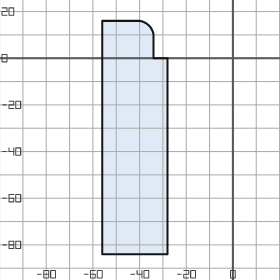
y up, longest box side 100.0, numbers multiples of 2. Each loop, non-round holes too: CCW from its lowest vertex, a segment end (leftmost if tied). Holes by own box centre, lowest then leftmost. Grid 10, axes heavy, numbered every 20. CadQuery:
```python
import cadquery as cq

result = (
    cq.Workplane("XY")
    .moveTo(-56.0, -84.0)
    .lineTo(-28.0, -84.0)
    .lineTo(-28.0, 0.0)
    .lineTo(-34.0, 0.0)
    .lineTo(-34.0, 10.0)
    .threePointArc((-36.0, 14.0), (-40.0, 16.0))
    .lineTo(-56.0, 16.0)
    .close()
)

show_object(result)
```